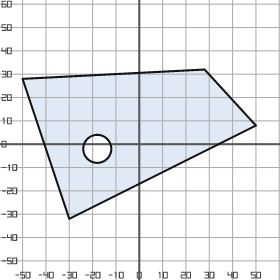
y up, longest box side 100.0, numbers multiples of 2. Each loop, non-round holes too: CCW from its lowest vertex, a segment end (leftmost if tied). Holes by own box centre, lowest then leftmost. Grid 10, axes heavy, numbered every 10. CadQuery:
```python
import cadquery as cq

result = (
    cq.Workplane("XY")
    .moveTo(-30.0, -32.0)
    .lineTo(50.0, 8.0)
    .lineTo(28.0, 32.0)
    .lineTo(-50.0, 28.0)
    .close()
    .moveTo(-18.0, -2.0)
    .circle(6.0)
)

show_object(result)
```